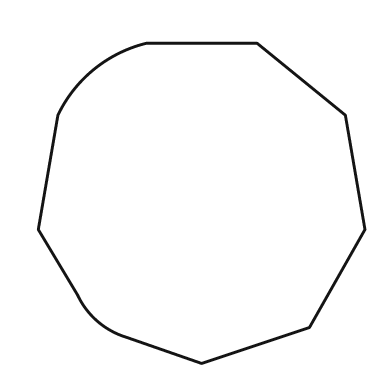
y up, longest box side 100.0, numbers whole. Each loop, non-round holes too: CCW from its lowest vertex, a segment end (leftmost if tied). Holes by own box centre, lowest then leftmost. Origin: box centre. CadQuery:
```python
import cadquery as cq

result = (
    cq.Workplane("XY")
    .moveTo(0.0, -49.0)
    .lineTo(33.0, -38.0)
    .lineTo(50.0, -8.0)
    .lineTo(44.0, 27.0)
    .lineTo(17.0, 49.0)
    .lineTo(-17.0, 49.0)
    .threePointArc((-33.0, 41.0), (-44.0, 27.0))
    .lineTo(-50.0, -8.0)
    .lineTo(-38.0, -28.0)
    .threePointArc((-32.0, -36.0), (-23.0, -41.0))
    .close()
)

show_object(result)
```